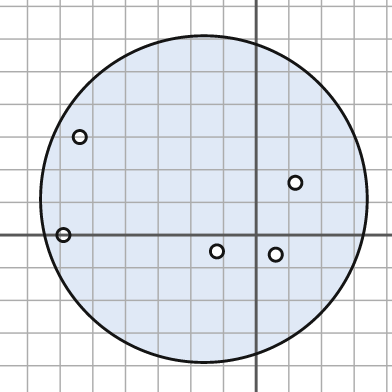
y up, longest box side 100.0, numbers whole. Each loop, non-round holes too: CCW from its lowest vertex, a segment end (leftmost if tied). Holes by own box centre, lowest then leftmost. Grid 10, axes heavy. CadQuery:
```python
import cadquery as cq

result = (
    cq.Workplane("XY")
    .moveTo(-16.0, 11.0)
    .circle(50.0)
    .moveTo(6.0, -6.0)
    .circle(2.0)
    .moveTo(-12.0, -5.0)
    .circle(2.0)
    .moveTo(-59.0, 0.0)
    .circle(2.0)
    .moveTo(12.0, 16.0)
    .circle(2.0)
    .moveTo(-54.0, 30.0)
    .circle(2.0)
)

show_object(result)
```